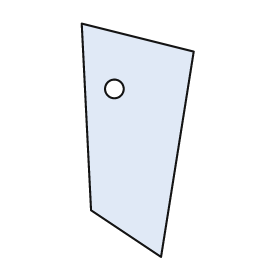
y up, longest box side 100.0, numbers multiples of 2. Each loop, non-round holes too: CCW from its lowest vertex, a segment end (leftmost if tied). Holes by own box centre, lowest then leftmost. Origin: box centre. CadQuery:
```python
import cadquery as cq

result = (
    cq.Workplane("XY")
    .moveTo(10.0, -50.0)
    .lineTo(24.0, 38.0)
    .lineTo(-24.0, 50.0)
    .lineTo(-20.0, -30.0)
    .close()
    .moveTo(-10.0, 22.0)
    .circle(4.0)
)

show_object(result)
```